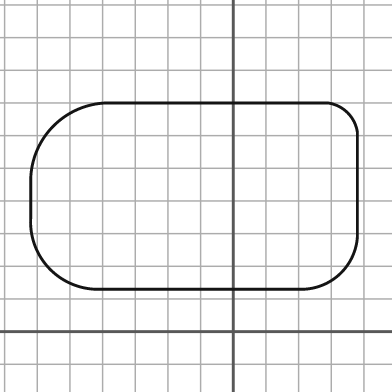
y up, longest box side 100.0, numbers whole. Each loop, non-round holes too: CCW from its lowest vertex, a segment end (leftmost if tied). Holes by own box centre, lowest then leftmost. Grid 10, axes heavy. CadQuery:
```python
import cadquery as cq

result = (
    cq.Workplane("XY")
    .moveTo(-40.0, 13.0)
    .lineTo(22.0, 13.0)
    .threePointArc((33.0, 18.0), (38.0, 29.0))
    .lineTo(38.0, 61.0)
    .threePointArc((35.0, 67.0), (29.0, 70.0))
    .lineTo(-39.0, 70.0)
    .threePointArc((-55.0, 63.0), (-62.0, 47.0))
    .lineTo(-62.0, 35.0)
    .threePointArc((-56.0, 19.0), (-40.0, 13.0))
    .close()
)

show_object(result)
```